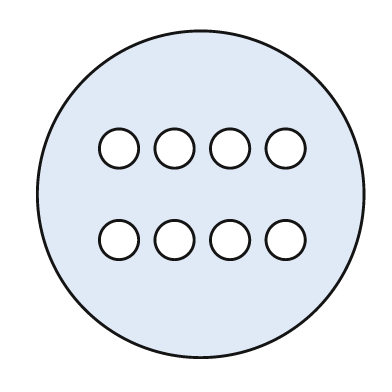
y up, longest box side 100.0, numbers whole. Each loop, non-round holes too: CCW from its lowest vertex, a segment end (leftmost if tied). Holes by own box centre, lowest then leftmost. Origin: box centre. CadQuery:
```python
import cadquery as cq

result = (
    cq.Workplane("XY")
    .moveTo(0.0, 0.0)
    .circle(50.0)
    .moveTo(-25.0, -14.0)
    .circle(6.0)
    .moveTo(-8.0, -14.0)
    .circle(6.0)
    .moveTo(9.0, -14.0)
    .circle(6.0)
    .moveTo(26.0, -14.0)
    .circle(6.0)
    .moveTo(-25.0, 14.0)
    .circle(6.0)
    .moveTo(-8.0, 14.0)
    .circle(6.0)
    .moveTo(9.0, 14.0)
    .circle(6.0)
    .moveTo(26.0, 14.0)
    .circle(6.0)
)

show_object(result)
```